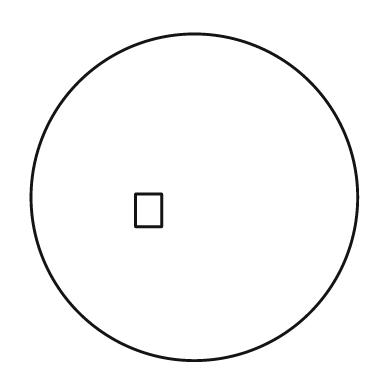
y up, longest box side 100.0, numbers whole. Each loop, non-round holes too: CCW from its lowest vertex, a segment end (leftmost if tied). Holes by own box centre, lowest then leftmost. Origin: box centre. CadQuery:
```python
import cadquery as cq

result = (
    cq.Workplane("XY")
    .moveTo(0.0, 0.0)
    .circle(50.0)
    .moveTo(-18.0, -9.0)
    .lineTo(-10.0, -9.0)
    .lineTo(-10.0, 1.0)
    .lineTo(-18.0, 1.0)
    .close()
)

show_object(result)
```